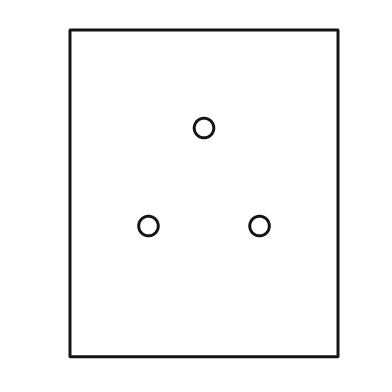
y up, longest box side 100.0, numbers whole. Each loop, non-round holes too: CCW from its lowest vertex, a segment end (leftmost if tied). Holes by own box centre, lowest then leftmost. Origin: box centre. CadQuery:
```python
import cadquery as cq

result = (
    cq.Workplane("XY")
    .moveTo(-41.0, -50.0)
    .lineTo(41.0, -50.0)
    .lineTo(41.0, 50.0)
    .lineTo(-41.0, 50.0)
    .close()
    .moveTo(-17.0, -10.0)
    .circle(3.0)
    .moveTo(17.0, -10.0)
    .circle(3.0)
    .moveTo(0.0, 20.0)
    .circle(3.0)
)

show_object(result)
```